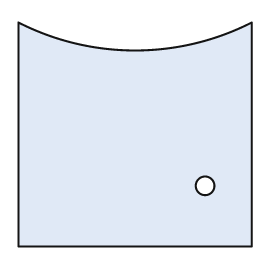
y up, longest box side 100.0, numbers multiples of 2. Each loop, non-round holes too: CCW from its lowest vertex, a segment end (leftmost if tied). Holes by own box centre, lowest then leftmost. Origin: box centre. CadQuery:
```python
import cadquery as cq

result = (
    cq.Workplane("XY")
    .moveTo(-50.0, -48.0)
    .lineTo(50.0, -48.0)
    .lineTo(50.0, 48.0)
    .threePointArc((0.0, 36.0), (-50.0, 48.0))
    .close()
    .moveTo(30.0, -22.0)
    .circle(4.0)
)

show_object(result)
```